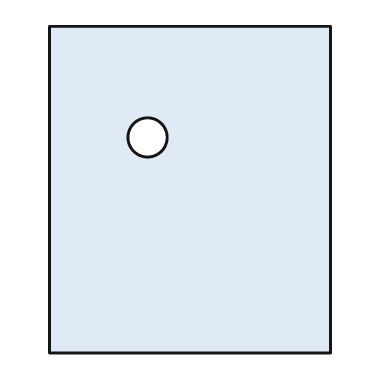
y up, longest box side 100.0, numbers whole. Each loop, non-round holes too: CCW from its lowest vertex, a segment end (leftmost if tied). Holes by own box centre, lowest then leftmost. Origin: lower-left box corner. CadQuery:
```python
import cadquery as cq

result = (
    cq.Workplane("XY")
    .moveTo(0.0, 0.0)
    .lineTo(86.0, 0.0)
    .lineTo(86.0, 100.0)
    .lineTo(0.0, 100.0)
    .close()
    .moveTo(30.0, 66.0)
    .circle(6.0)
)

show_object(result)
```